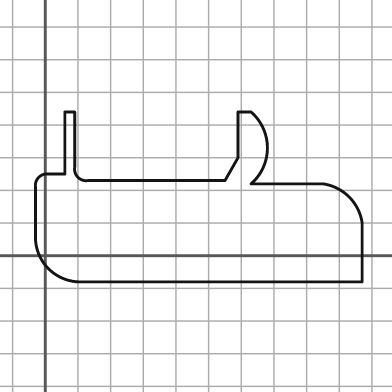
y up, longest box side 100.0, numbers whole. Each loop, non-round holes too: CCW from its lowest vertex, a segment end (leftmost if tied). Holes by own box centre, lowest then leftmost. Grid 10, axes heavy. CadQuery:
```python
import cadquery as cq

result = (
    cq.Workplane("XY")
    .moveTo(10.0, -8.0)
    .lineTo(97.0, -8.0)
    .lineTo(97.0, 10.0)
    .threePointArc((93.0, 18.0), (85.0, 22.0))
    .lineTo(63.0, 22.0)
    .threePointArc((68.0, 33.0), (63.0, 44.0))
    .lineTo(59.0, 44.0)
    .lineTo(59.0, 30.0)
    .lineTo(55.0, 23.0)
    .lineTo(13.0, 23.0)
    .threePointArc((10.0, 24.0), (9.0, 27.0))
    .lineTo(9.0, 44.0)
    .lineTo(6.0, 44.0)
    .lineTo(6.0, 25.0)
    .lineTo(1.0, 25.0)
    .threePointArc((-2.0, 24.0), (-3.0, 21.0))
    .lineTo(-3.0, 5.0)
    .threePointArc((1.0, -4.0), (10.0, -8.0))
    .close()
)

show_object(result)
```